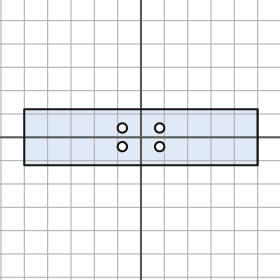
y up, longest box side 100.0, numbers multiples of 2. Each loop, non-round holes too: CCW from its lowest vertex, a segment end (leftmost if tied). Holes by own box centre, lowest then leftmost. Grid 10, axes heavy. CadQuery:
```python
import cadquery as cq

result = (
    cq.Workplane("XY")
    .moveTo(-50.0, -12.0)
    .lineTo(50.0, -12.0)
    .lineTo(50.0, 12.0)
    .lineTo(-50.0, 12.0)
    .close()
    .moveTo(-8.0, -4.0)
    .circle(2.0)
    .moveTo(8.0, -4.0)
    .circle(2.0)
    .moveTo(-8.0, 4.0)
    .circle(2.0)
    .moveTo(8.0, 4.0)
    .circle(2.0)
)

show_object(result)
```